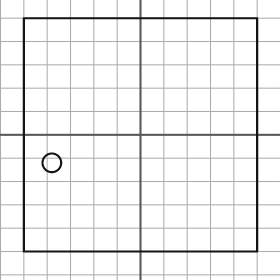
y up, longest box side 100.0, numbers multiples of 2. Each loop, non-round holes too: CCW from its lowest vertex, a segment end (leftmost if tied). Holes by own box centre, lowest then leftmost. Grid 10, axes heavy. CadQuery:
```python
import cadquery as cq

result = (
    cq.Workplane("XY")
    .moveTo(-50.0, -50.0)
    .lineTo(50.0, -50.0)
    .lineTo(50.0, 50.0)
    .lineTo(-50.0, 50.0)
    .close()
    .moveTo(-38.0, -12.0)
    .circle(4.0)
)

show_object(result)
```